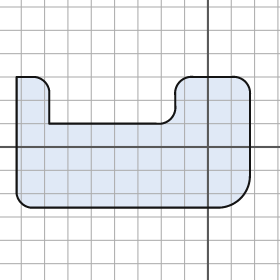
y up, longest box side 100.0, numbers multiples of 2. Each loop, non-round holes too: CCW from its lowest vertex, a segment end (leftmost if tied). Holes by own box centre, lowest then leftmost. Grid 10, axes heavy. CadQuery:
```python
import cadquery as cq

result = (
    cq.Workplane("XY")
    .moveTo(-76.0, -26.0)
    .lineTo(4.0, -26.0)
    .threePointArc((14.0, -22.0), (18.0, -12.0))
    .lineTo(18.0, 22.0)
    .threePointArc((16.0, 28.0), (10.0, 30.0))
    .lineTo(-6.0, 30.0)
    .threePointArc((-12.0, 28.0), (-14.0, 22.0))
    .lineTo(-14.0, 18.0)
    .threePointArc((-16.0, 12.0), (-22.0, 10.0))
    .lineTo(-68.0, 10.0)
    .lineTo(-68.0, 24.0)
    .threePointArc((-70.0, 28.0), (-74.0, 30.0))
    .lineTo(-82.0, 30.0)
    .lineTo(-82.0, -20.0)
    .threePointArc((-80.0, -24.0), (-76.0, -26.0))
    .close()
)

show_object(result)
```